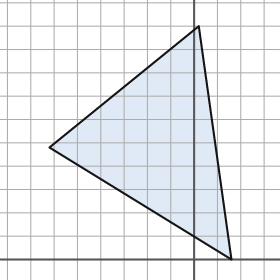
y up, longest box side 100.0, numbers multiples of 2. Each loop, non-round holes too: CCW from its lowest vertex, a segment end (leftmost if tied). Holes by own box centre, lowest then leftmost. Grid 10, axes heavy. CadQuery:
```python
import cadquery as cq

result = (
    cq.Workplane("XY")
    .moveTo(16.0, 0.0)
    .lineTo(2.0, 100.0)
    .lineTo(-62.0, 48.0)
    .close()
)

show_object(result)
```